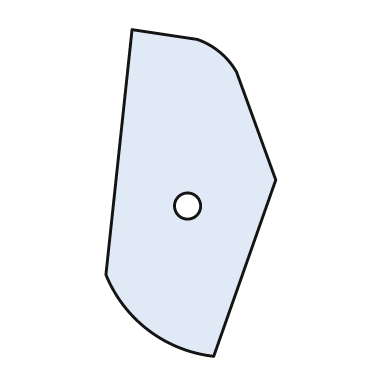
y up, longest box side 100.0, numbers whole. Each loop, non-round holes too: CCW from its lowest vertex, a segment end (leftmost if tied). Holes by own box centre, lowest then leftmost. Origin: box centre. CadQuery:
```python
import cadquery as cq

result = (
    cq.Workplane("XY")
    .moveTo(7.0, -50.0)
    .lineTo(26.0, 4.0)
    .lineTo(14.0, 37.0)
    .threePointArc((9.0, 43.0), (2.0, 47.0))
    .lineTo(-18.0, 50.0)
    .lineTo(-26.0, -25.0)
    .threePointArc((-13.0, -42.0), (7.0, -50.0))
    .close()
    .moveTo(-1.0, -4.0)
    .circle(4.0)
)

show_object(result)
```